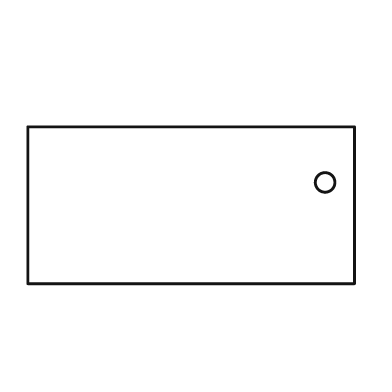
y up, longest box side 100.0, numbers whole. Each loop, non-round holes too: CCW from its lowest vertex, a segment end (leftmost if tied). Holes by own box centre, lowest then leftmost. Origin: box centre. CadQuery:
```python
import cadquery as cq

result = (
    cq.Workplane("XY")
    .moveTo(-50.0, -24.0)
    .lineTo(50.0, -24.0)
    .lineTo(50.0, 24.0)
    .lineTo(-50.0, 24.0)
    .close()
    .moveTo(41.0, 7.0)
    .circle(3.0)
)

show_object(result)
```